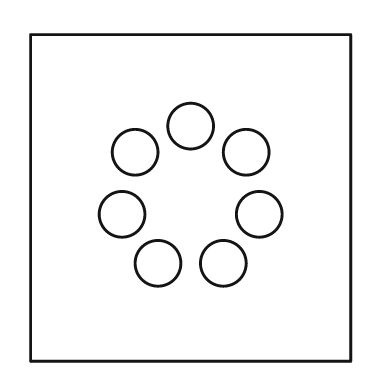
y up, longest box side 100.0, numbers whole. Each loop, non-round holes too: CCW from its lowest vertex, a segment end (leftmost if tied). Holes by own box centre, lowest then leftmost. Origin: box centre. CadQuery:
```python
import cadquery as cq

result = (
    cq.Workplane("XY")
    .moveTo(-49.0, -50.0)
    .lineTo(49.0, -50.0)
    .lineTo(49.0, 50.0)
    .lineTo(-49.0, 50.0)
    .close()
    .moveTo(-10.0, -20.0)
    .circle(7.0)
    .moveTo(10.0, -20.0)
    .circle(7.0)
    .moveTo(-21.0, -5.0)
    .circle(7.0)
    .moveTo(21.0, -5.0)
    .circle(7.0)
    .moveTo(-17.0, 14.0)
    .circle(7.0)
    .moveTo(17.0, 14.0)
    .circle(7.0)
    .moveTo(0.0, 22.0)
    .circle(7.0)
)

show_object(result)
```